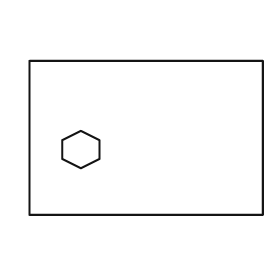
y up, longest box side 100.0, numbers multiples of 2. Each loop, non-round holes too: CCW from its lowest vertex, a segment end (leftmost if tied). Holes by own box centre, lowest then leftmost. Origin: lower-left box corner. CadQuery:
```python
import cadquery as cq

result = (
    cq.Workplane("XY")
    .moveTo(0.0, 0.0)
    .lineTo(100.0, 0.0)
    .lineTo(100.0, 66.0)
    .lineTo(0.0, 66.0)
    .close()
    .moveTo(22.0, 20.0)
    .lineTo(30.0, 24.0)
    .lineTo(30.0, 32.0)
    .lineTo(22.0, 36.0)
    .lineTo(14.0, 32.0)
    .lineTo(14.0, 24.0)
    .close()
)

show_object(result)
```